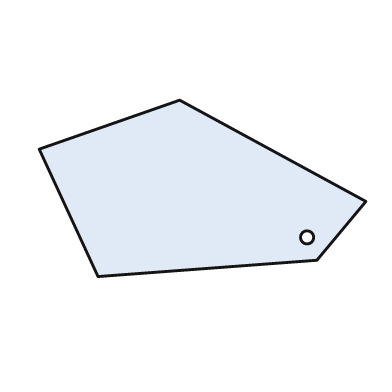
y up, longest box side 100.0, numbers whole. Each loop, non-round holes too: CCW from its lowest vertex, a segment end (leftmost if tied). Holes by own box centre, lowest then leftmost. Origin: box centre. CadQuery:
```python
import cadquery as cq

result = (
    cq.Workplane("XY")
    .moveTo(-32.0, -27.0)
    .lineTo(35.0, -22.0)
    .lineTo(50.0, -4.0)
    .lineTo(-7.0, 27.0)
    .lineTo(-50.0, 12.0)
    .close()
    .moveTo(32.0, -15.0)
    .circle(2.0)
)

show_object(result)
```